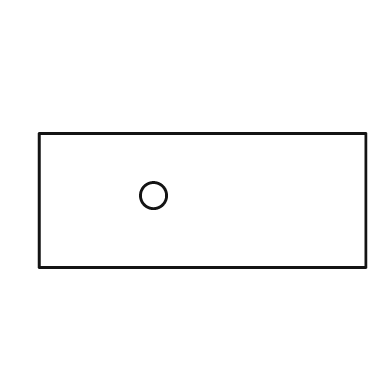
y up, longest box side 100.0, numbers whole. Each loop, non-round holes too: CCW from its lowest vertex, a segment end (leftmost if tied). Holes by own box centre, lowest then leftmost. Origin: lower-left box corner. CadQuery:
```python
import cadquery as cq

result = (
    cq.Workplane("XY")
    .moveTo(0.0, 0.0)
    .lineTo(100.0, 0.0)
    .lineTo(100.0, 41.0)
    .lineTo(0.0, 41.0)
    .close()
    .moveTo(35.0, 22.0)
    .circle(4.0)
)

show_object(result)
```